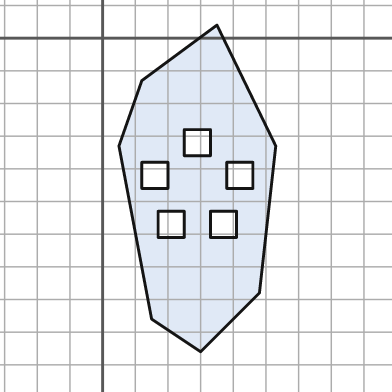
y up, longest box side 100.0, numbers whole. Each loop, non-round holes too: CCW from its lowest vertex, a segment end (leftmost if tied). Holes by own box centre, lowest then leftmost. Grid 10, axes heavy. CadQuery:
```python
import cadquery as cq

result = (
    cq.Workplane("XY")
    .moveTo(30.0, -96.0)
    .lineTo(48.0, -78.0)
    .lineTo(53.0, -33.0)
    .lineTo(35.0, 4.0)
    .lineTo(12.0, -13.0)
    .lineTo(5.0, -33.0)
    .lineTo(15.0, -86.0)
    .close()
    .moveTo(17.0, -61.0)
    .lineTo(25.0, -61.0)
    .lineTo(25.0, -53.0)
    .lineTo(17.0, -53.0)
    .close()
    .moveTo(33.0, -61.0)
    .lineTo(41.0, -61.0)
    .lineTo(41.0, -53.0)
    .lineTo(33.0, -53.0)
    .close()
    .moveTo(12.0, -46.0)
    .lineTo(20.0, -46.0)
    .lineTo(20.0, -38.0)
    .lineTo(12.0, -38.0)
    .close()
    .moveTo(38.0, -46.0)
    .lineTo(46.0, -46.0)
    .lineTo(46.0, -38.0)
    .lineTo(38.0, -38.0)
    .close()
    .moveTo(25.0, -36.0)
    .lineTo(33.0, -36.0)
    .lineTo(33.0, -28.0)
    .lineTo(25.0, -28.0)
    .close()
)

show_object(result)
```